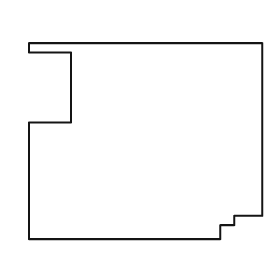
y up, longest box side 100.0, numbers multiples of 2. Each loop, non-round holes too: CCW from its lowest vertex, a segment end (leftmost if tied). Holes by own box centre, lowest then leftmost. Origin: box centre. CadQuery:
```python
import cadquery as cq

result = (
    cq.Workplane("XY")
    .moveTo(-50.0, -42.0)
    .lineTo(32.0, -42.0)
    .lineTo(32.0, -36.0)
    .lineTo(38.0, -36.0)
    .lineTo(38.0, -32.0)
    .lineTo(50.0, -32.0)
    .lineTo(50.0, 42.0)
    .lineTo(-50.0, 42.0)
    .lineTo(-50.0, 38.0)
    .lineTo(-32.0, 38.0)
    .lineTo(-32.0, 8.0)
    .lineTo(-50.0, 8.0)
    .close()
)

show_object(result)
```